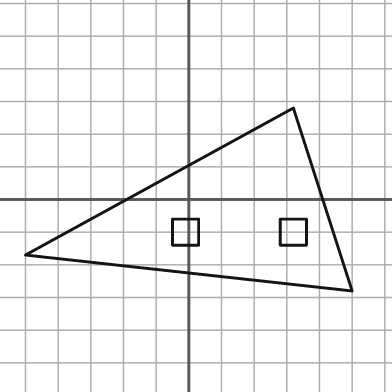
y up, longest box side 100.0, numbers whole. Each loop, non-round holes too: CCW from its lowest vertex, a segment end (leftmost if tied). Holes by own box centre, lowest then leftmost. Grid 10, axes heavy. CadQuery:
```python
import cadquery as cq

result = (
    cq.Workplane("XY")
    .moveTo(50.0, -28.0)
    .lineTo(32.0, 28.0)
    .lineTo(-50.0, -17.0)
    .close()
    .moveTo(-5.0, -14.0)
    .lineTo(3.0, -14.0)
    .lineTo(3.0, -6.0)
    .lineTo(-5.0, -6.0)
    .close()
    .moveTo(28.0, -14.0)
    .lineTo(36.0, -14.0)
    .lineTo(36.0, -6.0)
    .lineTo(28.0, -6.0)
    .close()
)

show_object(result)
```